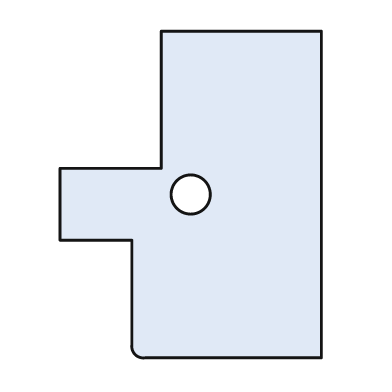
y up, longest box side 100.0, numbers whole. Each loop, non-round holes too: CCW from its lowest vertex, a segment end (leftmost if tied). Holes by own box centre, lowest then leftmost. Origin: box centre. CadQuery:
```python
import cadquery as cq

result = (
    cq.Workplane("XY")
    .moveTo(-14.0, -50.0)
    .lineTo(40.0, -50.0)
    .lineTo(40.0, 50.0)
    .lineTo(-9.0, 50.0)
    .lineTo(-9.0, 8.0)
    .lineTo(-40.0, 8.0)
    .lineTo(-40.0, -14.0)
    .lineTo(-18.0, -14.0)
    .lineTo(-18.0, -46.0)
    .threePointArc((-17.0, -49.0), (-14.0, -50.0))
    .close()
    .moveTo(0.0, 0.0)
    .circle(6.0)
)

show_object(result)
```